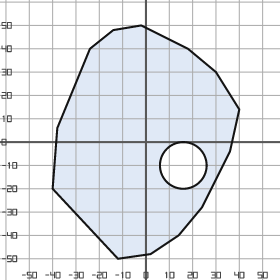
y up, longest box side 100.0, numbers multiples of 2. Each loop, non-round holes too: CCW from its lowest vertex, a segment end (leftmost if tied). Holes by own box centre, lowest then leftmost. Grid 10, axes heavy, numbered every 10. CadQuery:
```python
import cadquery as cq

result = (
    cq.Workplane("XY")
    .moveTo(-12.0, -50.0)
    .lineTo(2.0, -48.0)
    .lineTo(14.0, -40.0)
    .lineTo(24.0, -28.0)
    .lineTo(36.0, -4.0)
    .lineTo(40.0, 14.0)
    .lineTo(30.0, 30.0)
    .lineTo(18.0, 40.0)
    .lineTo(-2.0, 50.0)
    .lineTo(-14.0, 48.0)
    .lineTo(-24.0, 40.0)
    .lineTo(-38.0, 6.0)
    .lineTo(-40.0, -20.0)
    .close()
    .moveTo(16.0, -10.0)
    .circle(10.0)
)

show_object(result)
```